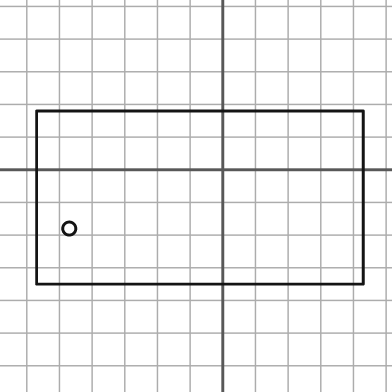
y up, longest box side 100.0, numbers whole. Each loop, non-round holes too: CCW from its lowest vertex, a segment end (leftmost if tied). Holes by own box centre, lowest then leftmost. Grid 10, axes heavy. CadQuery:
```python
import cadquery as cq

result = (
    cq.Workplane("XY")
    .moveTo(-57.0, -35.0)
    .lineTo(43.0, -35.0)
    .lineTo(43.0, 18.0)
    .lineTo(-57.0, 18.0)
    .close()
    .moveTo(-47.0, -18.0)
    .circle(2.0)
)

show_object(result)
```